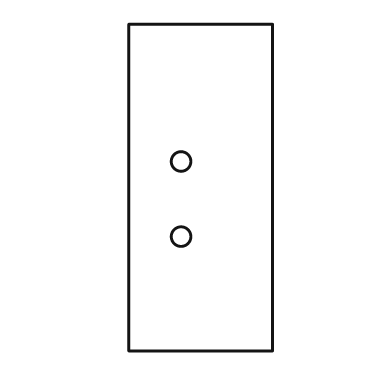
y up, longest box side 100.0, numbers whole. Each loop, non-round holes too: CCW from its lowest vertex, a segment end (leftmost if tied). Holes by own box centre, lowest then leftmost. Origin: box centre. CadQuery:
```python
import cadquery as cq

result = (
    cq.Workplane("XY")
    .moveTo(-22.0, -50.0)
    .lineTo(22.0, -50.0)
    .lineTo(22.0, 50.0)
    .lineTo(-22.0, 50.0)
    .close()
    .moveTo(-6.0, -15.0)
    .circle(3.0)
    .moveTo(-6.0, 8.0)
    .circle(3.0)
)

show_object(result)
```